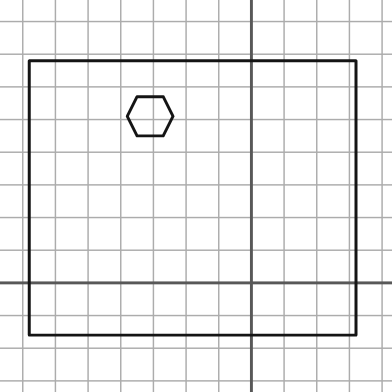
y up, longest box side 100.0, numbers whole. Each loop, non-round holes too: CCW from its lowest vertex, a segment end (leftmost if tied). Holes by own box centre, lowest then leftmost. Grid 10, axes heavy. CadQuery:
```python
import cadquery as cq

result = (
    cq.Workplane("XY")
    .moveTo(-68.0, -16.0)
    .lineTo(32.0, -16.0)
    .lineTo(32.0, 68.0)
    .lineTo(-68.0, 68.0)
    .close()
    .moveTo(-35.0, 45.0)
    .lineTo(-27.0, 45.0)
    .lineTo(-24.0, 51.0)
    .lineTo(-27.0, 57.0)
    .lineTo(-35.0, 57.0)
    .lineTo(-38.0, 51.0)
    .close()
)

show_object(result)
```